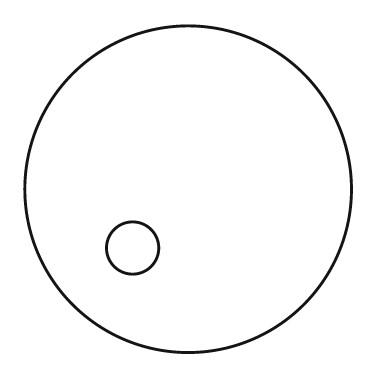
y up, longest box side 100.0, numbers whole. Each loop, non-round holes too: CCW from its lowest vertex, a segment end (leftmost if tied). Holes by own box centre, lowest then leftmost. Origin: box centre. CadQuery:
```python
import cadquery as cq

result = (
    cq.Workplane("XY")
    .moveTo(0.0, 0.0)
    .circle(50.0)
    .moveTo(-17.0, -18.0)
    .circle(8.0)
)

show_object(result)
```